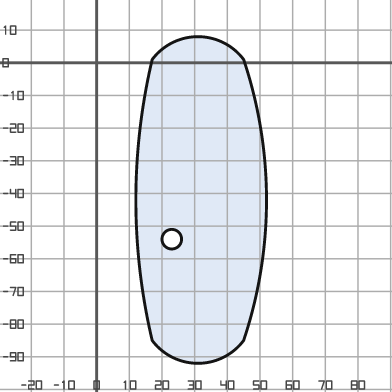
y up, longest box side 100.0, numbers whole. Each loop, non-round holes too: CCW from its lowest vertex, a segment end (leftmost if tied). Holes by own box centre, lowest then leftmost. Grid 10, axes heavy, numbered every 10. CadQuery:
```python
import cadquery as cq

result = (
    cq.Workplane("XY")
    .moveTo(17.0, -85.0)
    .threePointArc((31.0, -92.0), (45.0, -85.0))
    .threePointArc((52.0, -42.0), (45.0, 1.0))
    .threePointArc((31.0, 8.0), (17.0, 1.0))
    .threePointArc((12.0, -42.0), (17.0, -85.0))
    .close()
    .moveTo(23.0, -54.0)
    .circle(3.0)
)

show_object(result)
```